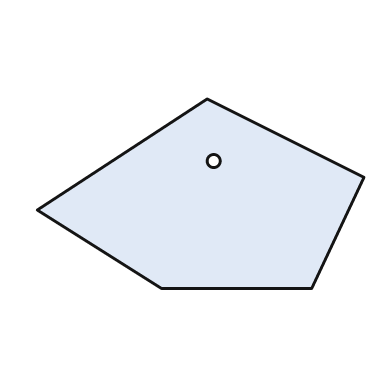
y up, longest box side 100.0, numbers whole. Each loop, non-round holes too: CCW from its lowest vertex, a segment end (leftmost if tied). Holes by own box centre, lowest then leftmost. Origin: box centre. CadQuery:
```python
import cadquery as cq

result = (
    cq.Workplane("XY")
    .moveTo(-12.0, -29.0)
    .lineTo(34.0, -29.0)
    .lineTo(50.0, 5.0)
    .lineTo(2.0, 29.0)
    .lineTo(-50.0, -5.0)
    .close()
    .moveTo(4.0, 10.0)
    .circle(2.0)
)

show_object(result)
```